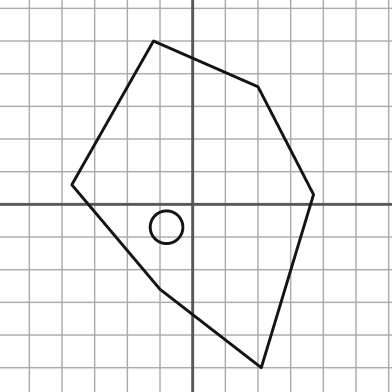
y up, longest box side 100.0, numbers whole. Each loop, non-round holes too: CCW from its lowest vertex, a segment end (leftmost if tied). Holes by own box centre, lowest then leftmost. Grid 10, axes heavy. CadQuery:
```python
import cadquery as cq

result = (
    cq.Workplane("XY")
    .moveTo(21.0, -50.0)
    .lineTo(37.0, 3.0)
    .lineTo(20.0, 36.0)
    .lineTo(-12.0, 50.0)
    .lineTo(-37.0, 6.0)
    .lineTo(-10.0, -26.0)
    .close()
    .moveTo(-8.0, -7.0)
    .circle(5.0)
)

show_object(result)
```